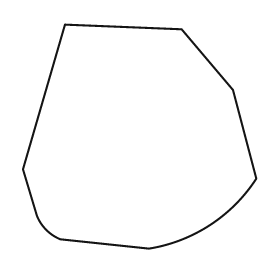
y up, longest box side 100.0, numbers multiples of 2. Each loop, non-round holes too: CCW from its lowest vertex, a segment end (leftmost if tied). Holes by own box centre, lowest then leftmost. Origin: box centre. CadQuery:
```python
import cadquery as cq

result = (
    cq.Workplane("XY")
    .moveTo(4.0, -48.0)
    .threePointArc((30.0, -38.0), (50.0, -18.0))
    .lineTo(40.0, 20.0)
    .lineTo(18.0, 46.0)
    .lineTo(-32.0, 48.0)
    .lineTo(-50.0, -14.0)
    .lineTo(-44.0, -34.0)
    .threePointArc((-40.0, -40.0), (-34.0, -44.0))
    .close()
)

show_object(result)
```